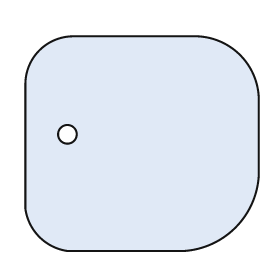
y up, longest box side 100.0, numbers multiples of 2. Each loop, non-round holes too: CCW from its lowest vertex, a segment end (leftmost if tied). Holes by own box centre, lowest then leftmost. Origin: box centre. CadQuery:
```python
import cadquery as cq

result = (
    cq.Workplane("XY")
    .moveTo(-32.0, -46.0)
    .lineTo(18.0, -46.0)
    .threePointArc((40.0, -36.0), (50.0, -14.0))
    .lineTo(50.0, 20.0)
    .threePointArc((42.0, 38.0), (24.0, 46.0))
    .lineTo(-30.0, 46.0)
    .threePointArc((-44.0, 40.0), (-50.0, 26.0))
    .lineTo(-50.0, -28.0)
    .threePointArc((-44.0, -40.0), (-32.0, -46.0))
    .close()
    .moveTo(-32.0, 4.0)
    .circle(4.0)
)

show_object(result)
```